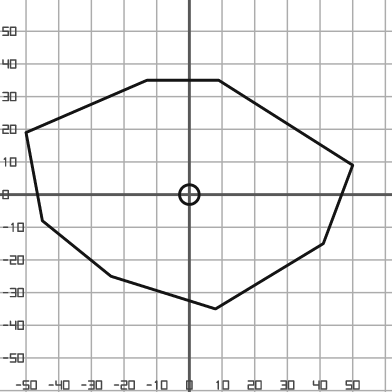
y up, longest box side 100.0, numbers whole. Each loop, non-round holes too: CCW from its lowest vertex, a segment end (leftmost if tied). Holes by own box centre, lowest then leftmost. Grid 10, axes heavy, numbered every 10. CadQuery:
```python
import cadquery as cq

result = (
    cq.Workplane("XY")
    .moveTo(8.0, -35.0)
    .lineTo(41.0, -15.0)
    .lineTo(50.0, 9.0)
    .lineTo(9.0, 35.0)
    .lineTo(-13.0, 35.0)
    .lineTo(-50.0, 19.0)
    .lineTo(-45.0, -8.0)
    .lineTo(-24.0, -25.0)
    .close()
    .moveTo(0.0, 0.0)
    .circle(3.0)
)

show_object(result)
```